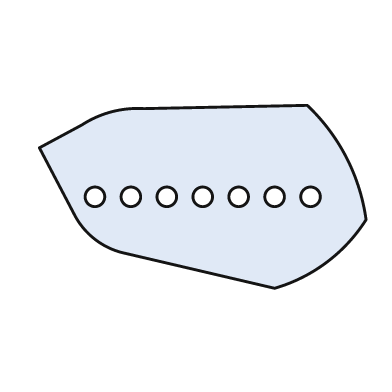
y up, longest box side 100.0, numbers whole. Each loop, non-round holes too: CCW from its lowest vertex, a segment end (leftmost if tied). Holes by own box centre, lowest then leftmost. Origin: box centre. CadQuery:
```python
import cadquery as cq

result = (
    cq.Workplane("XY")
    .moveTo(22.0, -28.0)
    .threePointArc((38.0, -20.0), (50.0, -7.0))
    .threePointArc((44.0, 12.0), (32.0, 28.0))
    .lineTo(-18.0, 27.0)
    .threePointArc((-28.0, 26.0), (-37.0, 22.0))
    .lineTo(-50.0, 15.0)
    .lineTo(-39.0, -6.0)
    .threePointArc((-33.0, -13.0), (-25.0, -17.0))
    .close()
    .moveTo(-33.0, 0.0)
    .circle(3.0)
    .moveTo(-22.0, 0.0)
    .circle(3.0)
    .moveTo(-11.0, 0.0)
    .circle(3.0)
    .moveTo(0.0, 0.0)
    .circle(3.0)
    .moveTo(11.0, 0.0)
    .circle(3.0)
    .moveTo(22.0, 0.0)
    .circle(3.0)
    .moveTo(33.0, 0.0)
    .circle(3.0)
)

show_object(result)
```